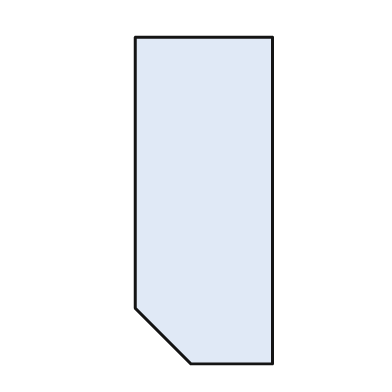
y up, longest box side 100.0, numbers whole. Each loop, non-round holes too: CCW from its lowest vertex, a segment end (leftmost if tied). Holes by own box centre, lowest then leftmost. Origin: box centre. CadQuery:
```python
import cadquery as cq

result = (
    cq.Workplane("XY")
    .moveTo(-4.0, -50.0)
    .lineTo(21.0, -50.0)
    .lineTo(21.0, 50.0)
    .lineTo(-21.0, 50.0)
    .lineTo(-21.0, -33.0)
    .close()
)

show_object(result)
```